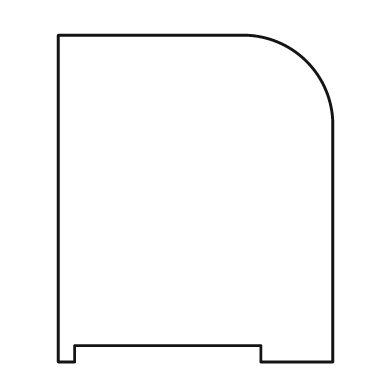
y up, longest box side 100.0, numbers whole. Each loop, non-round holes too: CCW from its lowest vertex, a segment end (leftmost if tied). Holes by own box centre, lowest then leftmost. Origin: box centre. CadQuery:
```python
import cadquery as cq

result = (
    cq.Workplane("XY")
    .moveTo(-42.0, -50.0)
    .lineTo(-37.0, -50.0)
    .lineTo(-37.0, -45.0)
    .lineTo(20.0, -45.0)
    .lineTo(20.0, -50.0)
    .lineTo(42.0, -50.0)
    .lineTo(42.0, 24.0)
    .threePointArc((34.0, 42.0), (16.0, 50.0))
    .lineTo(-42.0, 50.0)
    .close()
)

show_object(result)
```